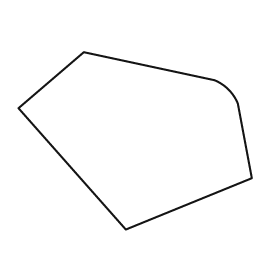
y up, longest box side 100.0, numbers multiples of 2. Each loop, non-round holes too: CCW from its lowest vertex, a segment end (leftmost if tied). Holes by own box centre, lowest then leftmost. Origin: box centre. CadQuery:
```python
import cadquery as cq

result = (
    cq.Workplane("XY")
    .moveTo(-4.0, -38.0)
    .lineTo(50.0, -16.0)
    .lineTo(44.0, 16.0)
    .threePointArc((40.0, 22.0), (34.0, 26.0))
    .lineTo(-22.0, 38.0)
    .lineTo(-50.0, 14.0)
    .close()
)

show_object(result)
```